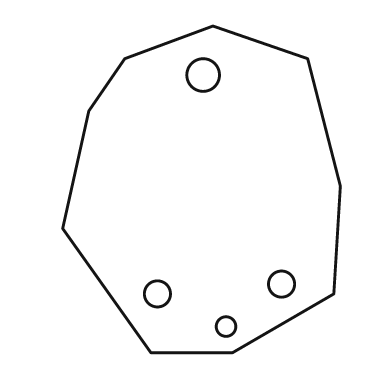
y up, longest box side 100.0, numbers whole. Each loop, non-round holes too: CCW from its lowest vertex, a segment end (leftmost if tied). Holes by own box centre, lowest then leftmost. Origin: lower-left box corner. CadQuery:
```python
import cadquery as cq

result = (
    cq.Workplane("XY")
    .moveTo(27.0, 0.0)
    .lineTo(52.0, 0.0)
    .lineTo(83.0, 18.0)
    .lineTo(85.0, 51.0)
    .lineTo(75.0, 90.0)
    .lineTo(46.0, 100.0)
    .lineTo(19.0, 90.0)
    .lineTo(8.0, 74.0)
    .lineTo(0.0, 38.0)
    .close()
    .moveTo(50.0, 8.0)
    .circle(3.0)
    .moveTo(29.0, 18.0)
    .circle(4.0)
    .moveTo(67.0, 21.0)
    .circle(4.0)
    .moveTo(43.0, 85.0)
    .circle(5.0)
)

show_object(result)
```